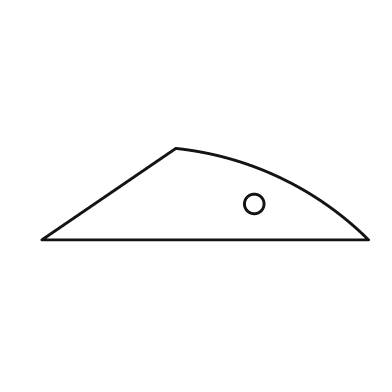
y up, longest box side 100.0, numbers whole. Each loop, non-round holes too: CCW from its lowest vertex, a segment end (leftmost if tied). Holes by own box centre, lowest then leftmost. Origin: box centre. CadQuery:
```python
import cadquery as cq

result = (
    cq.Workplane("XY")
    .moveTo(-50.0, -14.0)
    .lineTo(50.0, -14.0)
    .threePointArc((23.0, 5.0), (-9.0, 14.0))
    .close()
    .moveTo(15.0, -3.0)
    .circle(3.0)
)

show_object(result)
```